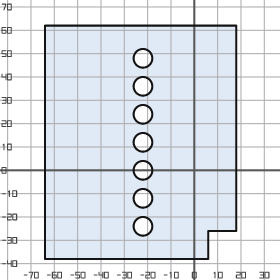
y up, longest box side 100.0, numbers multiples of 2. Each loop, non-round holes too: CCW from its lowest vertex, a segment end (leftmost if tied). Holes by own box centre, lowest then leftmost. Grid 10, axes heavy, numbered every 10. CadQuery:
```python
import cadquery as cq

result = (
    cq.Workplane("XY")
    .moveTo(-64.0, -38.0)
    .lineTo(6.0, -38.0)
    .lineTo(6.0, -26.0)
    .lineTo(18.0, -26.0)
    .lineTo(18.0, 62.0)
    .lineTo(-64.0, 62.0)
    .close()
    .moveTo(-22.0, -24.0)
    .circle(4.0)
    .moveTo(-22.0, -12.0)
    .circle(4.0)
    .moveTo(-22.0, 0.0)
    .circle(4.0)
    .moveTo(-22.0, 12.0)
    .circle(4.0)
    .moveTo(-22.0, 24.0)
    .circle(4.0)
    .moveTo(-22.0, 36.0)
    .circle(4.0)
    .moveTo(-22.0, 48.0)
    .circle(4.0)
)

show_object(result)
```